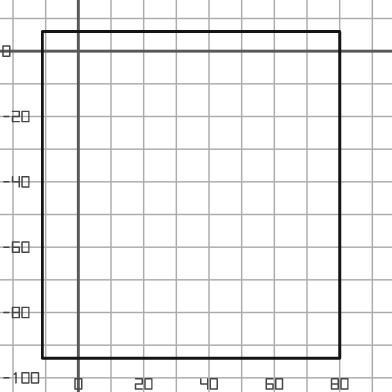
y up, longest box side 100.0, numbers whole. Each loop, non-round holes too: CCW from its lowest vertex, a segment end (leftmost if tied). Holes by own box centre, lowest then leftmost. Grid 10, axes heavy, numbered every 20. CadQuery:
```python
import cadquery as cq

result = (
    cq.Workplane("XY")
    .moveTo(-11.0, -94.0)
    .lineTo(80.0, -94.0)
    .lineTo(80.0, 6.0)
    .lineTo(-11.0, 6.0)
    .close()
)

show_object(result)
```